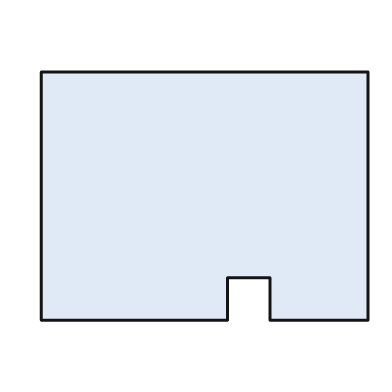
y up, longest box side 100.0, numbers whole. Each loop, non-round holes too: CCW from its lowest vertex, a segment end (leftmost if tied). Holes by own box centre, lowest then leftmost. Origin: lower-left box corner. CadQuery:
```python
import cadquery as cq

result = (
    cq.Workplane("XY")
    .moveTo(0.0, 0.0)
    .lineTo(57.0, 0.0)
    .lineTo(57.0, 13.0)
    .lineTo(70.0, 13.0)
    .lineTo(70.0, 0.0)
    .lineTo(100.0, 0.0)
    .lineTo(100.0, 76.0)
    .lineTo(0.0, 76.0)
    .close()
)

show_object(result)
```